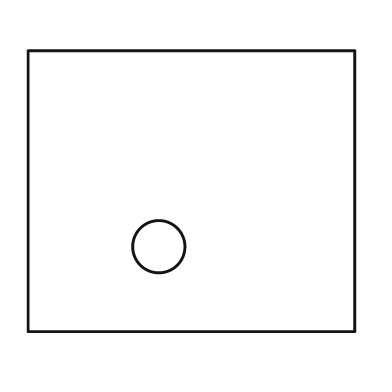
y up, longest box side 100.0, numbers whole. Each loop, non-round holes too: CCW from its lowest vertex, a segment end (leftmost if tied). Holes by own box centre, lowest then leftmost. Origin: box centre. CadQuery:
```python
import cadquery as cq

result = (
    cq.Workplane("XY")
    .moveTo(-50.0, -43.0)
    .lineTo(50.0, -43.0)
    .lineTo(50.0, 43.0)
    .lineTo(-50.0, 43.0)
    .close()
    .moveTo(-10.0, -17.0)
    .circle(8.0)
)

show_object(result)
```